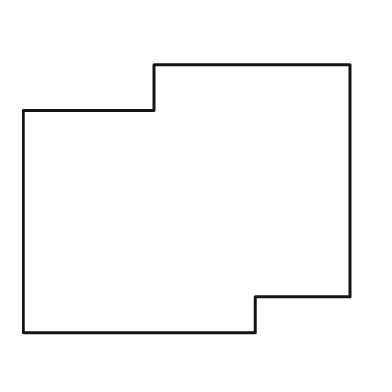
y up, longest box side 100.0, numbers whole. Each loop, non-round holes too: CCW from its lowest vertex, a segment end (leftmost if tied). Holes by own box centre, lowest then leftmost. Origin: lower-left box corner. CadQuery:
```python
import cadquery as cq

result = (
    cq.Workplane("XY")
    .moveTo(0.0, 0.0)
    .lineTo(71.0, 0.0)
    .lineTo(71.0, 11.0)
    .lineTo(100.0, 11.0)
    .lineTo(100.0, 82.0)
    .lineTo(40.0, 82.0)
    .lineTo(40.0, 68.0)
    .lineTo(0.0, 68.0)
    .close()
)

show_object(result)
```